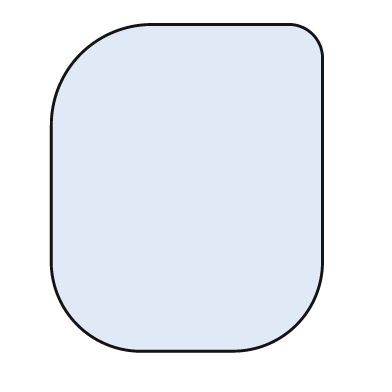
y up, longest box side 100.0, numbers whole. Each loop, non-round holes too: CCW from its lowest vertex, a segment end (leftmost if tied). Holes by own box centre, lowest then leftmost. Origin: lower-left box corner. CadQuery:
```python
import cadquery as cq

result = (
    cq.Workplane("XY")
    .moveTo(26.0, 0.0)
    .lineTo(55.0, 0.0)
    .threePointArc((75.0, 8.0), (83.0, 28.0))
    .lineTo(83.0, 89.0)
    .threePointArc((80.0, 97.0), (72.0, 100.0))
    .lineTo(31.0, 100.0)
    .threePointArc((9.0, 91.0), (0.0, 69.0))
    .lineTo(0.0, 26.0)
    .threePointArc((8.0, 8.0), (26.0, 0.0))
    .close()
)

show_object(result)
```